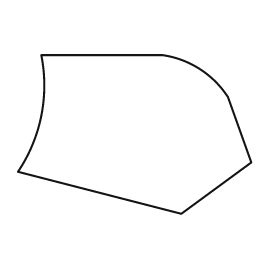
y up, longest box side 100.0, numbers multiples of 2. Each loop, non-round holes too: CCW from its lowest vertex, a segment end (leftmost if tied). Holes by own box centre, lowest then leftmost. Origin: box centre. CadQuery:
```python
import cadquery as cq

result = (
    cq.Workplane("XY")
    .moveTo(20.0, -34.0)
    .lineTo(50.0, -12.0)
    .lineTo(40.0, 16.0)
    .threePointArc((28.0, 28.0), (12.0, 34.0))
    .lineTo(-40.0, 34.0)
    .threePointArc((-40.0, 8.0), (-50.0, -16.0))
    .close()
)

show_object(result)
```